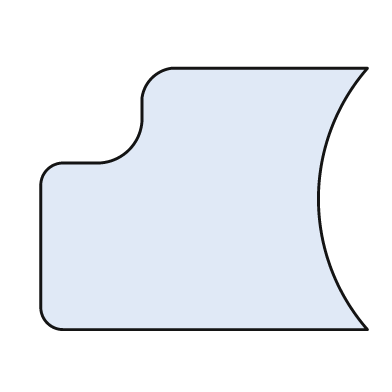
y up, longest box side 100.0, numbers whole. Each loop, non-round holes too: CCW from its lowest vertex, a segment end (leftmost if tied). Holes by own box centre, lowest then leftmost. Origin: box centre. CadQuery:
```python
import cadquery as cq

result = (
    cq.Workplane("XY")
    .moveTo(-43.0, -40.0)
    .lineTo(50.0, -40.0)
    .threePointArc((35.0, 0.0), (50.0, 40.0))
    .lineTo(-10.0, 40.0)
    .threePointArc((-16.0, 37.0), (-19.0, 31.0))
    .lineTo(-19.0, 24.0)
    .threePointArc((-23.0, 15.0), (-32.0, 11.0))
    .lineTo(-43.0, 11.0)
    .threePointArc((-48.0, 9.0), (-50.0, 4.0))
    .lineTo(-50.0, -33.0)
    .threePointArc((-48.0, -38.0), (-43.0, -40.0))
    .close()
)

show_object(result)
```